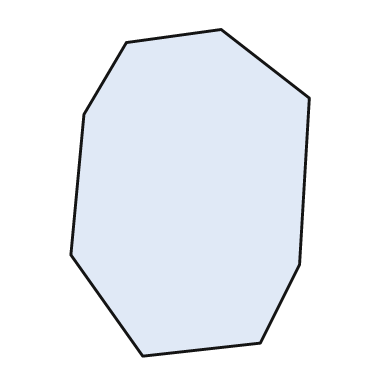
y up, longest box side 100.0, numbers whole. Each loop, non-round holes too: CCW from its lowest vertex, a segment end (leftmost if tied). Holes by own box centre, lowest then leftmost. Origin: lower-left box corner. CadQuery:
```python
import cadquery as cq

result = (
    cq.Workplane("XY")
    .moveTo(22.0, 0.0)
    .lineTo(58.0, 4.0)
    .lineTo(70.0, 28.0)
    .lineTo(73.0, 79.0)
    .lineTo(46.0, 100.0)
    .lineTo(17.0, 96.0)
    .lineTo(4.0, 74.0)
    .lineTo(0.0, 31.0)
    .close()
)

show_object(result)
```